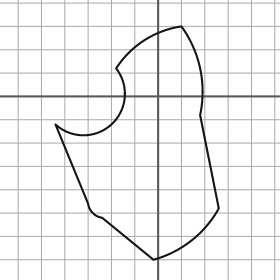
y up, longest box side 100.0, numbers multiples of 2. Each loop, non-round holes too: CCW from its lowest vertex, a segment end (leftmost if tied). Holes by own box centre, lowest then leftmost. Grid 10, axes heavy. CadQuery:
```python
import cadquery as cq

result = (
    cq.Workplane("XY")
    .moveTo(-2.0, -70.0)
    .threePointArc((14.0, -62.0), (26.0, -48.0))
    .lineTo(18.0, -8.0)
    .threePointArc((18.0, 12.0), (10.0, 30.0))
    .threePointArc((-6.0, 24.0), (-18.0, 12.0))
    .threePointArc((-20.0, -12.0), (-44.0, -12.0))
    .lineTo(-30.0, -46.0)
    .threePointArc((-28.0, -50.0), (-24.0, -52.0))
    .close()
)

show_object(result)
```